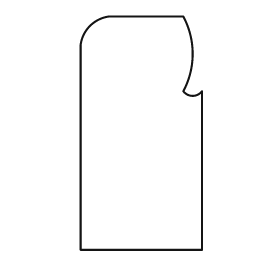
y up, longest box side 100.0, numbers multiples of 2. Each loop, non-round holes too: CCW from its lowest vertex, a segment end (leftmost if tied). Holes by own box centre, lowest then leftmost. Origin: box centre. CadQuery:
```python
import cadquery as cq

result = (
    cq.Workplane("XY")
    .moveTo(-26.0, -50.0)
    .lineTo(26.0, -50.0)
    .lineTo(26.0, 18.0)
    .threePointArc((22.0, 16.0), (18.0, 18.0))
    .threePointArc((22.0, 34.0), (18.0, 50.0))
    .lineTo(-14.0, 50.0)
    .threePointArc((-22.0, 46.0), (-26.0, 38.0))
    .close()
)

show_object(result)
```